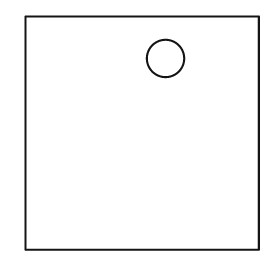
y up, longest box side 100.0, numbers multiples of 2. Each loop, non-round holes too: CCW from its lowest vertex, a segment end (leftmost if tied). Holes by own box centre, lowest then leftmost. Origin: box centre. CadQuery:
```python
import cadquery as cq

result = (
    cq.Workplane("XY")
    .moveTo(-50.0, -50.0)
    .lineTo(50.0, -50.0)
    .lineTo(50.0, 50.0)
    .lineTo(-50.0, 50.0)
    .close()
    .moveTo(10.0, 32.0)
    .circle(8.0)
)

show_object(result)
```